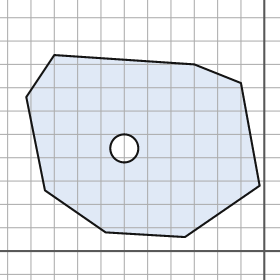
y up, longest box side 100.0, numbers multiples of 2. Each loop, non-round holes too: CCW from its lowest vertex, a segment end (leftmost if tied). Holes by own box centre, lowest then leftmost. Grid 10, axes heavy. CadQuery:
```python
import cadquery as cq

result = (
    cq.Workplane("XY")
    .moveTo(-34.0, 6.0)
    .lineTo(-2.0, 28.0)
    .lineTo(-10.0, 72.0)
    .lineTo(-30.0, 80.0)
    .lineTo(-90.0, 84.0)
    .lineTo(-102.0, 66.0)
    .lineTo(-94.0, 26.0)
    .lineTo(-68.0, 8.0)
    .close()
    .moveTo(-60.0, 44.0)
    .circle(6.0)
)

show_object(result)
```